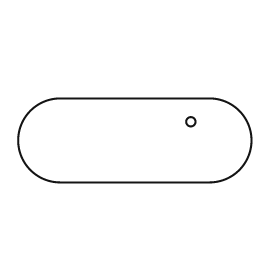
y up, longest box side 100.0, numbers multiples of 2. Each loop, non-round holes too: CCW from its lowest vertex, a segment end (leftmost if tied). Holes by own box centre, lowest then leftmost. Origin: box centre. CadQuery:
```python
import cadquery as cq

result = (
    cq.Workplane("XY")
    .moveTo(-32.0, -18.0)
    .lineTo(32.0, -18.0)
    .threePointArc((50.0, 0.0), (32.0, 18.0))
    .lineTo(-32.0, 18.0)
    .threePointArc((-50.0, 0.0), (-32.0, -18.0))
    .close()
    .moveTo(24.0, 8.0)
    .circle(2.0)
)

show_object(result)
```